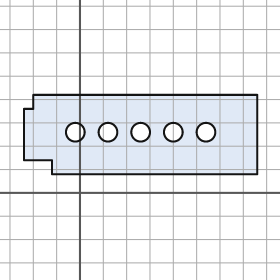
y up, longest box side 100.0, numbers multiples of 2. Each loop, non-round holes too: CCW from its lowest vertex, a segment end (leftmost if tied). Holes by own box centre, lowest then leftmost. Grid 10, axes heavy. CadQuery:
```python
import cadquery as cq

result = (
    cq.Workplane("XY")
    .moveTo(-12.0, 8.0)
    .lineTo(76.0, 8.0)
    .lineTo(76.0, 42.0)
    .lineTo(-20.0, 42.0)
    .lineTo(-20.0, 36.0)
    .lineTo(-24.0, 36.0)
    .lineTo(-24.0, 14.0)
    .lineTo(-12.0, 14.0)
    .close()
    .moveTo(-2.0, 26.0)
    .circle(4.0)
    .moveTo(12.0, 26.0)
    .circle(4.0)
    .moveTo(26.0, 26.0)
    .circle(4.0)
    .moveTo(40.0, 26.0)
    .circle(4.0)
    .moveTo(54.0, 26.0)
    .circle(4.0)
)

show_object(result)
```